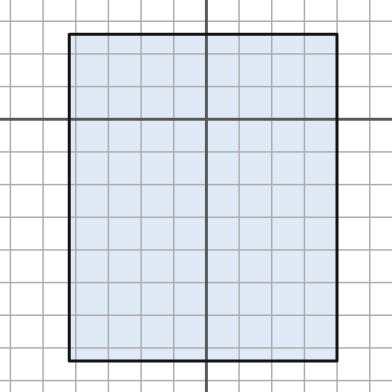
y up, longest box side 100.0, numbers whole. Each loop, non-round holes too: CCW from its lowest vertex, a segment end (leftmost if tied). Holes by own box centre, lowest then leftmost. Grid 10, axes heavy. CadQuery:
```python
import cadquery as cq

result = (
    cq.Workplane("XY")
    .moveTo(-42.0, -74.0)
    .lineTo(40.0, -74.0)
    .lineTo(40.0, 26.0)
    .lineTo(-42.0, 26.0)
    .close()
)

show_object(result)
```